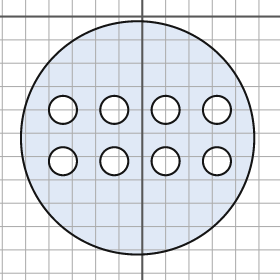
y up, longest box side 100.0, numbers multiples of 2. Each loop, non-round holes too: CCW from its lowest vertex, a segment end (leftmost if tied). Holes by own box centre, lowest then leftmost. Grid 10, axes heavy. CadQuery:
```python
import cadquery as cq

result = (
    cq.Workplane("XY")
    .moveTo(-2.0, -52.0)
    .circle(50.0)
    .moveTo(-34.0, -62.0)
    .circle(6.0)
    .moveTo(-12.0, -62.0)
    .circle(6.0)
    .moveTo(10.0, -62.0)
    .circle(6.0)
    .moveTo(32.0, -62.0)
    .circle(6.0)
    .moveTo(-34.0, -40.0)
    .circle(6.0)
    .moveTo(-12.0, -40.0)
    .circle(6.0)
    .moveTo(10.0, -40.0)
    .circle(6.0)
    .moveTo(32.0, -40.0)
    .circle(6.0)
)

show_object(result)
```